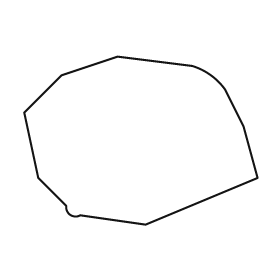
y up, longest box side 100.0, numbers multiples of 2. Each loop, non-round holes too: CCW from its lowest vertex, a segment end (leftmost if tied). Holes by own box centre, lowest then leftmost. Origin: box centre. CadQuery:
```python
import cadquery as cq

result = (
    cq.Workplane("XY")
    .moveTo(2.0, -36.0)
    .lineTo(50.0, -16.0)
    .lineTo(44.0, 6.0)
    .lineTo(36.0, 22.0)
    .threePointArc((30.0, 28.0), (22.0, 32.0))
    .lineTo(-10.0, 36.0)
    .lineTo(-34.0, 28.0)
    .lineTo(-50.0, 12.0)
    .lineTo(-44.0, -16.0)
    .lineTo(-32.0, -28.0)
    .threePointArc((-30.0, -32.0), (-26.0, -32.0))
    .close()
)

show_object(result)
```